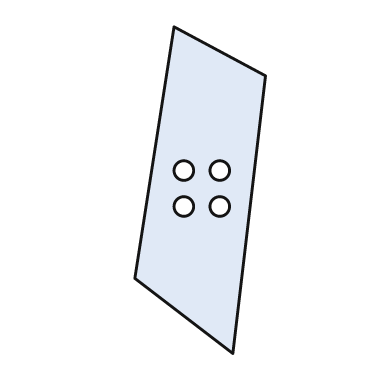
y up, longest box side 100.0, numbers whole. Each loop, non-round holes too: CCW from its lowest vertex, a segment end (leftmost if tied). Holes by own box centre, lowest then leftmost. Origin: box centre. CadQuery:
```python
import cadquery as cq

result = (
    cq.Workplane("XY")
    .moveTo(10.0, -50.0)
    .lineTo(20.0, 35.0)
    .lineTo(-8.0, 50.0)
    .lineTo(-20.0, -27.0)
    .close()
    .moveTo(-5.0, -5.0)
    .circle(3.0)
    .moveTo(6.0, -5.0)
    .circle(3.0)
    .moveTo(-5.0, 6.0)
    .circle(3.0)
    .moveTo(6.0, 6.0)
    .circle(3.0)
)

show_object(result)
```